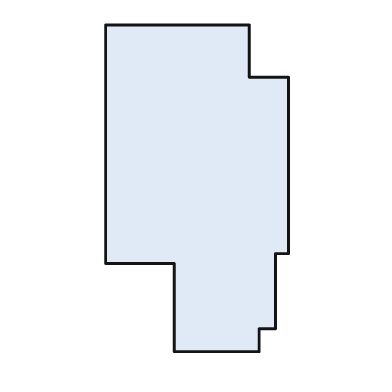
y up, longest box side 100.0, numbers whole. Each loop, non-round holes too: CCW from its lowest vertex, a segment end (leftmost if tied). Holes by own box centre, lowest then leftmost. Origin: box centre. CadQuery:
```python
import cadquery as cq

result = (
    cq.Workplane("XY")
    .moveTo(-7.0, -50.0)
    .lineTo(19.0, -50.0)
    .lineTo(19.0, -43.0)
    .lineTo(24.0, -43.0)
    .lineTo(24.0, -20.0)
    .lineTo(28.0, -20.0)
    .lineTo(28.0, 34.0)
    .lineTo(16.0, 34.0)
    .lineTo(16.0, 50.0)
    .lineTo(-28.0, 50.0)
    .lineTo(-28.0, -23.0)
    .lineTo(-7.0, -23.0)
    .close()
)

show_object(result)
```